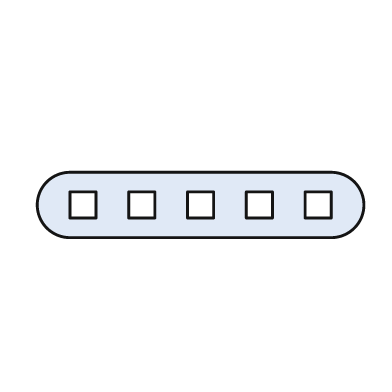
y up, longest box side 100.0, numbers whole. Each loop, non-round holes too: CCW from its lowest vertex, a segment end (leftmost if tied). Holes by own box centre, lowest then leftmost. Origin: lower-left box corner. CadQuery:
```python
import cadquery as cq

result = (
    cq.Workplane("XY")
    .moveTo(10.0, 0.0)
    .lineTo(90.0, 0.0)
    .threePointArc((100.0, 10.0), (90.0, 20.0))
    .lineTo(10.0, 20.0)
    .threePointArc((0.0, 10.0), (10.0, 0.0))
    .close()
    .moveTo(10.0, 6.0)
    .lineTo(18.0, 6.0)
    .lineTo(18.0, 14.0)
    .lineTo(10.0, 14.0)
    .close()
    .moveTo(28.0, 6.0)
    .lineTo(36.0, 6.0)
    .lineTo(36.0, 14.0)
    .lineTo(28.0, 14.0)
    .close()
    .moveTo(46.0, 6.0)
    .lineTo(54.0, 6.0)
    .lineTo(54.0, 14.0)
    .lineTo(46.0, 14.0)
    .close()
    .moveTo(64.0, 6.0)
    .lineTo(72.0, 6.0)
    .lineTo(72.0, 14.0)
    .lineTo(64.0, 14.0)
    .close()
    .moveTo(82.0, 6.0)
    .lineTo(90.0, 6.0)
    .lineTo(90.0, 14.0)
    .lineTo(82.0, 14.0)
    .close()
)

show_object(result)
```